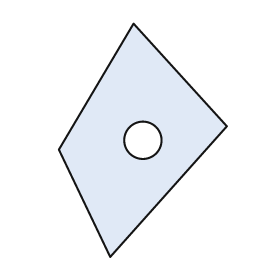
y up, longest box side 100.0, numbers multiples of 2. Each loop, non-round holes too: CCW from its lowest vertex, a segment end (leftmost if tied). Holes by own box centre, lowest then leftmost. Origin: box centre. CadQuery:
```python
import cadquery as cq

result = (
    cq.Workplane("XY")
    .moveTo(-14.0, -50.0)
    .lineTo(36.0, 6.0)
    .lineTo(-4.0, 50.0)
    .lineTo(-36.0, -4.0)
    .close()
    .moveTo(0.0, 0.0)
    .circle(8.0)
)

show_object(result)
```